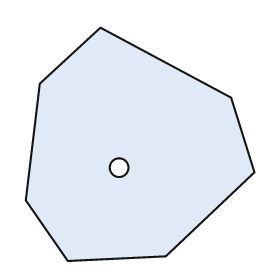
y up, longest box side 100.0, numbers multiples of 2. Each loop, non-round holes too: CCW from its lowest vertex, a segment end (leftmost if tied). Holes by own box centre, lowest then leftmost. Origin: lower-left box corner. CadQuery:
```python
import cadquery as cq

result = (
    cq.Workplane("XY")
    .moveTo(18.0, 0.0)
    .lineTo(60.0, 2.0)
    .lineTo(98.0, 38.0)
    .lineTo(88.0, 70.0)
    .lineTo(32.0, 100.0)
    .lineTo(6.0, 76.0)
    .lineTo(0.0, 26.0)
    .close()
    .moveTo(40.0, 40.0)
    .circle(4.0)
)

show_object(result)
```